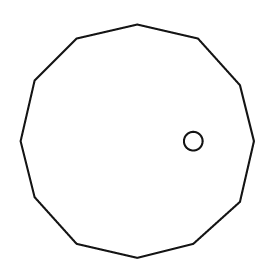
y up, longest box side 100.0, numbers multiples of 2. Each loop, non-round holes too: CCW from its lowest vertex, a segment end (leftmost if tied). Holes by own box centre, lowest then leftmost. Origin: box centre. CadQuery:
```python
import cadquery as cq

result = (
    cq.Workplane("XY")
    .moveTo(0.0, -50.0)
    .lineTo(24.0, -44.0)
    .lineTo(44.0, -26.0)
    .lineTo(50.0, 0.0)
    .lineTo(44.0, 24.0)
    .lineTo(26.0, 44.0)
    .lineTo(0.0, 50.0)
    .lineTo(-26.0, 44.0)
    .lineTo(-44.0, 26.0)
    .lineTo(-50.0, 0.0)
    .lineTo(-44.0, -24.0)
    .lineTo(-26.0, -44.0)
    .close()
    .moveTo(24.0, 0.0)
    .circle(4.0)
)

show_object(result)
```